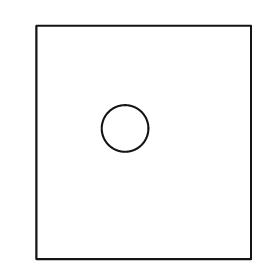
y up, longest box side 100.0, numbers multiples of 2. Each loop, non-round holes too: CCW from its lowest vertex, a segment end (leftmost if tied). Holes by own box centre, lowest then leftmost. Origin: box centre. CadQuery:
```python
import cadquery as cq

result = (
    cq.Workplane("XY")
    .moveTo(-46.0, -50.0)
    .lineTo(46.0, -50.0)
    .lineTo(46.0, 50.0)
    .lineTo(-46.0, 50.0)
    .close()
    .moveTo(-8.0, 6.0)
    .circle(10.0)
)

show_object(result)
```